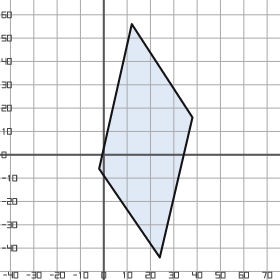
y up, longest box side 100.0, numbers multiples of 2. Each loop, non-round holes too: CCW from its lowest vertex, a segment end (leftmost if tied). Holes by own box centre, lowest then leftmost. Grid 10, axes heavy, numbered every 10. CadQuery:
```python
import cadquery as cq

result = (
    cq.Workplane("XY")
    .moveTo(24.0, -44.0)
    .lineTo(38.0, 16.0)
    .lineTo(12.0, 56.0)
    .lineTo(-2.0, -6.0)
    .close()
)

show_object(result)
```